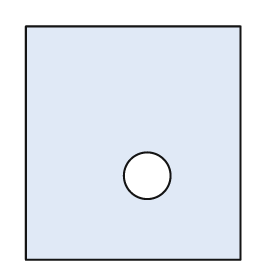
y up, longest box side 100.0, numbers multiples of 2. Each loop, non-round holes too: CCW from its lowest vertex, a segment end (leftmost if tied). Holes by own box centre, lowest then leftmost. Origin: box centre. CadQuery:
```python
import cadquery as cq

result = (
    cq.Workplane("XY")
    .moveTo(-46.0, -50.0)
    .lineTo(46.0, -50.0)
    .lineTo(46.0, 50.0)
    .lineTo(-46.0, 50.0)
    .close()
    .moveTo(6.0, -14.0)
    .circle(10.0)
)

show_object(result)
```